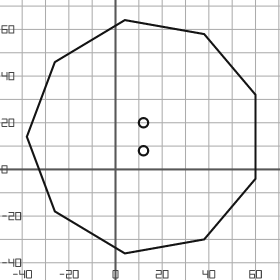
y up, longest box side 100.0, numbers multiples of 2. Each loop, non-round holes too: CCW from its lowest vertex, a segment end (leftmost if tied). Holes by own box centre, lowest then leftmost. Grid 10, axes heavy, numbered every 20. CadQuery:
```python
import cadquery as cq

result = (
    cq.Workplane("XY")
    .moveTo(4.0, -36.0)
    .lineTo(38.0, -30.0)
    .lineTo(60.0, -4.0)
    .lineTo(60.0, 32.0)
    .lineTo(38.0, 58.0)
    .lineTo(4.0, 64.0)
    .lineTo(-26.0, 46.0)
    .lineTo(-38.0, 14.0)
    .lineTo(-26.0, -18.0)
    .close()
    .moveTo(12.0, 8.0)
    .circle(2.0)
    .moveTo(12.0, 20.0)
    .circle(2.0)
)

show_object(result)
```